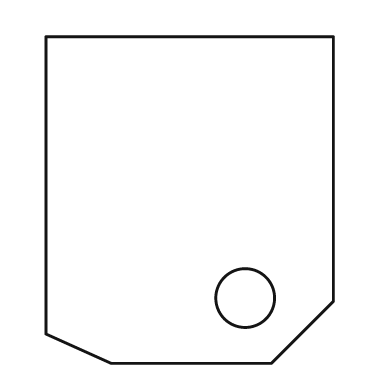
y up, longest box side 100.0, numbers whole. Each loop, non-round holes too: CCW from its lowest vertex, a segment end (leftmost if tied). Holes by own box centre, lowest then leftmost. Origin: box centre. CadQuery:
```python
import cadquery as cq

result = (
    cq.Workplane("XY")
    .moveTo(-24.0, -50.0)
    .lineTo(25.0, -50.0)
    .lineTo(44.0, -31.0)
    .lineTo(44.0, 50.0)
    .lineTo(-44.0, 50.0)
    .lineTo(-44.0, -41.0)
    .close()
    .moveTo(17.0, -30.0)
    .circle(9.0)
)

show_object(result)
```